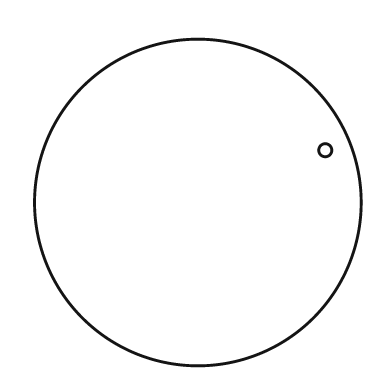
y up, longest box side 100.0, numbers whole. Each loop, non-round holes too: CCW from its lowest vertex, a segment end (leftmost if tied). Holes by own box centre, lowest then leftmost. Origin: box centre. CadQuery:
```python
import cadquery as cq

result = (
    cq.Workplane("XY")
    .moveTo(0.0, 0.0)
    .circle(50.0)
    .moveTo(39.0, 16.0)
    .circle(2.0)
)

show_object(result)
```